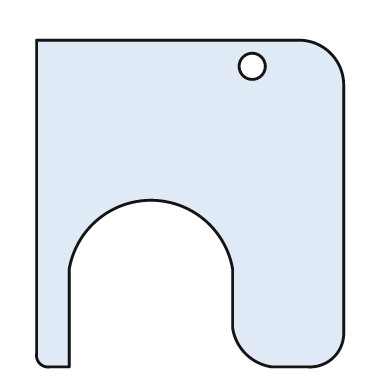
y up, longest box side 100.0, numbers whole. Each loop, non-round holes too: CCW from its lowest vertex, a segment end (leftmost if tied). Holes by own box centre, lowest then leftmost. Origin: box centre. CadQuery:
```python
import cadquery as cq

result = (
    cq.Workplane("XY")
    .moveTo(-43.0, -50.0)
    .lineTo(-37.0, -50.0)
    .lineTo(-37.0, -20.0)
    .threePointArc((-12.0, 1.0), (13.0, -20.0))
    .lineTo(13.0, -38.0)
    .threePointArc((17.0, -46.0), (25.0, -50.0))
    .lineTo(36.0, -50.0)
    .threePointArc((44.0, -47.0), (47.0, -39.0))
    .lineTo(47.0, 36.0)
    .threePointArc((43.0, 46.0), (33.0, 50.0))
    .lineTo(-47.0, 50.0)
    .lineTo(-47.0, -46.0)
    .threePointArc((-46.0, -49.0), (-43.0, -50.0))
    .close()
    .moveTo(19.0, 42.0)
    .circle(4.0)
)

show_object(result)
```